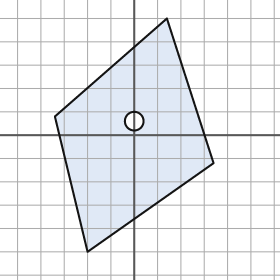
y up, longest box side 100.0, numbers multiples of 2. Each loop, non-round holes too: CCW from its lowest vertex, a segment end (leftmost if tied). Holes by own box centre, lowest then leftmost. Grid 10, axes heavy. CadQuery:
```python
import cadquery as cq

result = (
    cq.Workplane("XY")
    .moveTo(-20.0, -50.0)
    .lineTo(34.0, -12.0)
    .lineTo(14.0, 50.0)
    .lineTo(-34.0, 8.0)
    .close()
    .moveTo(0.0, 6.0)
    .circle(4.0)
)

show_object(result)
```